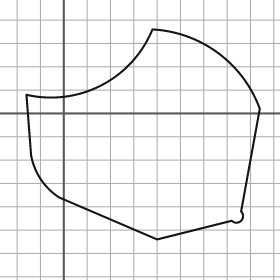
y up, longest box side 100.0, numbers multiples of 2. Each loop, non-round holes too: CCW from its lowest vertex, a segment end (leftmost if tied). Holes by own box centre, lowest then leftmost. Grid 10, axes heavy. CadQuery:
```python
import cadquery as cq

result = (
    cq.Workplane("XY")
    .moveTo(40.0, -54.0)
    .lineTo(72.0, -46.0)
    .threePointArc((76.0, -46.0), (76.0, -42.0))
    .lineTo(84.0, 2.0)
    .threePointArc((66.0, 26.0), (38.0, 36.0))
    .threePointArc((16.0, 12.0), (-16.0, 8.0))
    .lineTo(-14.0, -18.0)
    .threePointArc((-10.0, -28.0), (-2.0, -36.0))
    .close()
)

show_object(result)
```